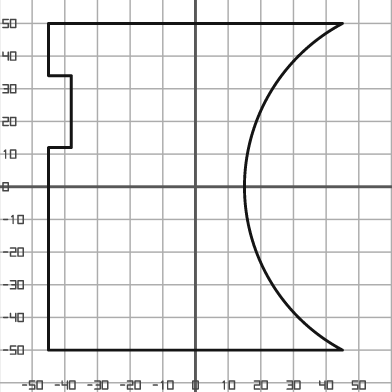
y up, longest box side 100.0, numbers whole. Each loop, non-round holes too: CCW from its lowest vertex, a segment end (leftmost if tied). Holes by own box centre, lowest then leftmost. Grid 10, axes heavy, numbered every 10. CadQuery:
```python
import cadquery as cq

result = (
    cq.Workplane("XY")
    .moveTo(-45.0, -50.0)
    .lineTo(45.0, -50.0)
    .threePointArc((15.0, 0.0), (45.0, 50.0))
    .lineTo(-45.0, 50.0)
    .lineTo(-45.0, 34.0)
    .lineTo(-38.0, 34.0)
    .lineTo(-38.0, 12.0)
    .lineTo(-45.0, 12.0)
    .close()
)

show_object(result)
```